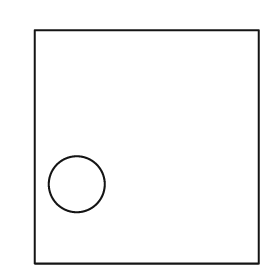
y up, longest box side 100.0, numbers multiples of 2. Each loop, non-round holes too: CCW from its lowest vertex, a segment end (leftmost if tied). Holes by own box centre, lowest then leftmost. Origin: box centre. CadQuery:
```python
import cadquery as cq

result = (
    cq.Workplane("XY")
    .moveTo(-48.0, -50.0)
    .lineTo(48.0, -50.0)
    .lineTo(48.0, 50.0)
    .lineTo(-48.0, 50.0)
    .close()
    .moveTo(-30.0, -16.0)
    .circle(12.0)
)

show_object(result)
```